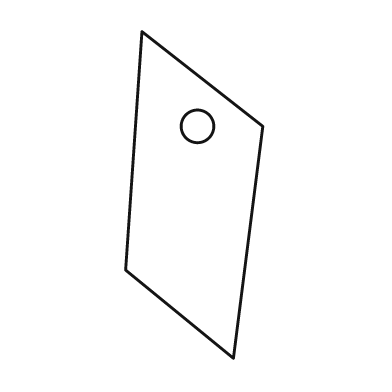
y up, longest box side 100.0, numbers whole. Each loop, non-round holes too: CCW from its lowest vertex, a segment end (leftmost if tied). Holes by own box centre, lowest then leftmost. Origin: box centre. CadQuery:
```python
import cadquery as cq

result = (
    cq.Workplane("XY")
    .moveTo(12.0, -50.0)
    .lineTo(21.0, 21.0)
    .lineTo(-16.0, 50.0)
    .lineTo(-21.0, -23.0)
    .close()
    .moveTo(1.0, 21.0)
    .circle(5.0)
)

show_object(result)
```